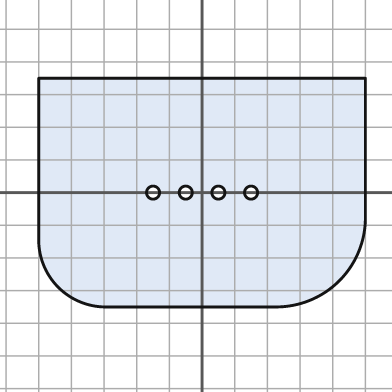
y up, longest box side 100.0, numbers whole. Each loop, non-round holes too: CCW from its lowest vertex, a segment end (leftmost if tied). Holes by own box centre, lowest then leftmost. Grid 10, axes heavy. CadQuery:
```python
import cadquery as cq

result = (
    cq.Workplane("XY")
    .moveTo(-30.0, -35.0)
    .lineTo(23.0, -35.0)
    .threePointArc((42.0, -27.0), (50.0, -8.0))
    .lineTo(50.0, 35.0)
    .lineTo(-50.0, 35.0)
    .lineTo(-50.0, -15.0)
    .threePointArc((-44.0, -29.0), (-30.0, -35.0))
    .close()
    .moveTo(-15.0, 0.0)
    .circle(2.0)
    .moveTo(-5.0, 0.0)
    .circle(2.0)
    .moveTo(5.0, 0.0)
    .circle(2.0)
    .moveTo(15.0, 0.0)
    .circle(2.0)
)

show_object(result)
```